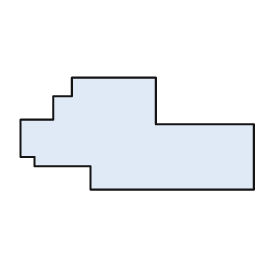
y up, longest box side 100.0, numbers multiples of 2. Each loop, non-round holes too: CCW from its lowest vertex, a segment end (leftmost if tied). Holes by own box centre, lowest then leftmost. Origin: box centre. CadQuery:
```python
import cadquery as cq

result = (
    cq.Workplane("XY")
    .moveTo(-20.0, -24.0)
    .lineTo(50.0, -24.0)
    .lineTo(50.0, 4.0)
    .lineTo(8.0, 4.0)
    .lineTo(8.0, 24.0)
    .lineTo(-28.0, 24.0)
    .lineTo(-28.0, 16.0)
    .lineTo(-36.0, 16.0)
    .lineTo(-36.0, 6.0)
    .lineTo(-50.0, 6.0)
    .lineTo(-50.0, -10.0)
    .lineTo(-44.0, -10.0)
    .lineTo(-44.0, -14.0)
    .lineTo(-20.0, -14.0)
    .close()
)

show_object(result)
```